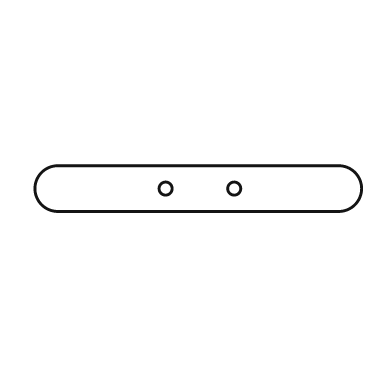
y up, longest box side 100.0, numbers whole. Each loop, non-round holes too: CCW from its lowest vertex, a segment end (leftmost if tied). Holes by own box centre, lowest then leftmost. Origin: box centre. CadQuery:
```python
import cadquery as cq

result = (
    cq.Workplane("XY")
    .moveTo(-43.0, -7.0)
    .lineTo(43.0, -7.0)
    .threePointArc((50.0, 0.0), (43.0, 7.0))
    .lineTo(-43.0, 7.0)
    .threePointArc((-50.0, 0.0), (-43.0, -7.0))
    .close()
    .moveTo(-10.0, 0.0)
    .circle(2.0)
    .moveTo(11.0, 0.0)
    .circle(2.0)
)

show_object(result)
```